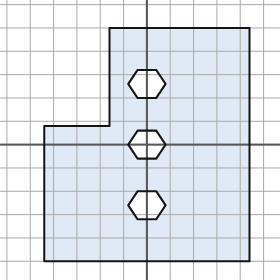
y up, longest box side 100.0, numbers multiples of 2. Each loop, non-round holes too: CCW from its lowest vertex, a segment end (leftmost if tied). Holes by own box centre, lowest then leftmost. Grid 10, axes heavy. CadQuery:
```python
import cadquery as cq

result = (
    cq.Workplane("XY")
    .moveTo(-44.0, -50.0)
    .lineTo(44.0, -50.0)
    .lineTo(44.0, 50.0)
    .lineTo(-16.0, 50.0)
    .lineTo(-16.0, 8.0)
    .lineTo(-44.0, 8.0)
    .close()
    .moveTo(-4.0, -32.0)
    .lineTo(4.0, -32.0)
    .lineTo(8.0, -26.0)
    .lineTo(4.0, -20.0)
    .lineTo(-4.0, -20.0)
    .lineTo(-8.0, -26.0)
    .close()
    .moveTo(-4.0, -6.0)
    .lineTo(4.0, -6.0)
    .lineTo(8.0, 0.0)
    .lineTo(4.0, 6.0)
    .lineTo(-4.0, 6.0)
    .lineTo(-8.0, 0.0)
    .close()
    .moveTo(-4.0, 20.0)
    .lineTo(4.0, 20.0)
    .lineTo(8.0, 26.0)
    .lineTo(4.0, 32.0)
    .lineTo(-4.0, 32.0)
    .lineTo(-8.0, 26.0)
    .close()
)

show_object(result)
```